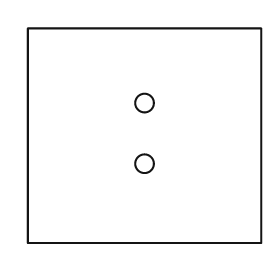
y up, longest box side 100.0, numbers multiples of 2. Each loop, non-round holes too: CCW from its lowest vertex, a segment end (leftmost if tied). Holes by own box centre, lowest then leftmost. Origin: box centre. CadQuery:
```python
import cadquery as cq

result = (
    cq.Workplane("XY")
    .moveTo(-50.0, -46.0)
    .lineTo(50.0, -46.0)
    .lineTo(50.0, 46.0)
    .lineTo(-50.0, 46.0)
    .close()
    .moveTo(0.0, -12.0)
    .circle(4.0)
    .moveTo(0.0, 14.0)
    .circle(4.0)
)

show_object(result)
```